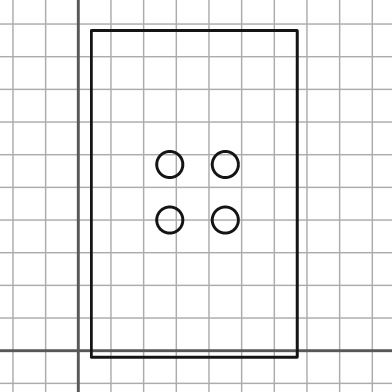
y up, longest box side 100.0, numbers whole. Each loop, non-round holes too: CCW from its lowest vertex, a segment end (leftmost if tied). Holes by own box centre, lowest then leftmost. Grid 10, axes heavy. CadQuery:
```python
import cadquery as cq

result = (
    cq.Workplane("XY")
    .moveTo(4.0, -2.0)
    .lineTo(67.0, -2.0)
    .lineTo(67.0, 98.0)
    .lineTo(4.0, 98.0)
    .close()
    .moveTo(28.0, 40.0)
    .circle(4.0)
    .moveTo(45.0, 40.0)
    .circle(4.0)
    .moveTo(28.0, 57.0)
    .circle(4.0)
    .moveTo(45.0, 57.0)
    .circle(4.0)
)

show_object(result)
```